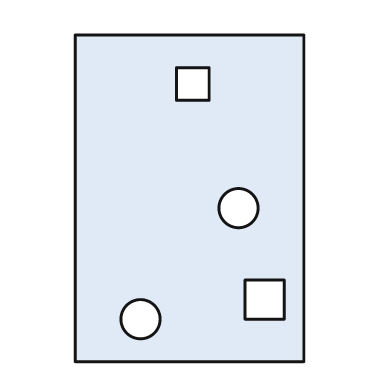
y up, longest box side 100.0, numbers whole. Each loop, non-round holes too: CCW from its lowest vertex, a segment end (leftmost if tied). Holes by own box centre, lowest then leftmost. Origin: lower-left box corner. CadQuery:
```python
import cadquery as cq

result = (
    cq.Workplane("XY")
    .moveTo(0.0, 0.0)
    .lineTo(70.0, 0.0)
    .lineTo(70.0, 100.0)
    .lineTo(0.0, 100.0)
    .close()
    .moveTo(20.0, 13.0)
    .circle(6.0)
    .moveTo(52.0, 13.0)
    .lineTo(64.0, 13.0)
    .lineTo(64.0, 25.0)
    .lineTo(52.0, 25.0)
    .close()
    .moveTo(50.0, 47.0)
    .circle(6.0)
    .moveTo(31.0, 80.0)
    .lineTo(41.0, 80.0)
    .lineTo(41.0, 90.0)
    .lineTo(31.0, 90.0)
    .close()
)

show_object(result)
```